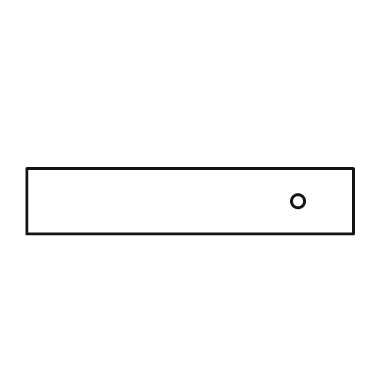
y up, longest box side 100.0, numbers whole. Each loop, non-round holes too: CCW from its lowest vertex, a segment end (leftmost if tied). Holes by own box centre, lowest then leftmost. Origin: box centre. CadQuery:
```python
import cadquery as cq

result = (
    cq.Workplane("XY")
    .moveTo(-50.0, -10.0)
    .lineTo(50.0, -10.0)
    .lineTo(50.0, 10.0)
    .lineTo(-50.0, 10.0)
    .close()
    .moveTo(33.0, 0.0)
    .circle(2.0)
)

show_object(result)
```